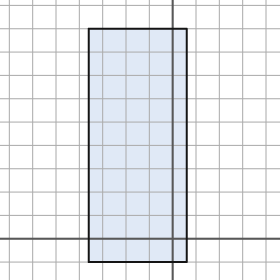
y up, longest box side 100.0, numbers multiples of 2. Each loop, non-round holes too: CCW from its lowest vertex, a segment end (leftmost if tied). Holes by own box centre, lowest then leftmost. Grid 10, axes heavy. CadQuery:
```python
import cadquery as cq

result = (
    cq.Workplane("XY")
    .moveTo(-36.0, -10.0)
    .lineTo(6.0, -10.0)
    .lineTo(6.0, 90.0)
    .lineTo(-36.0, 90.0)
    .close()
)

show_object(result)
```